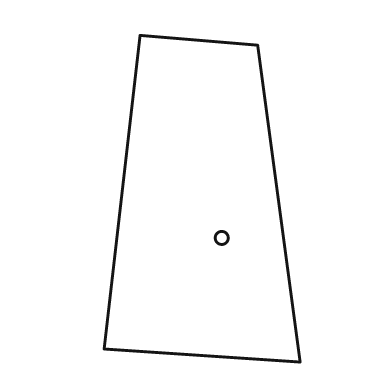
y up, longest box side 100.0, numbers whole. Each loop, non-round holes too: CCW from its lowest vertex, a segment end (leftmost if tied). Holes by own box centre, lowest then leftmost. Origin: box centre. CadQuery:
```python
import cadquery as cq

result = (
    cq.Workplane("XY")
    .moveTo(30.0, -50.0)
    .lineTo(17.0, 47.0)
    .lineTo(-19.0, 50.0)
    .lineTo(-30.0, -46.0)
    .close()
    .moveTo(6.0, -12.0)
    .circle(2.0)
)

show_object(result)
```